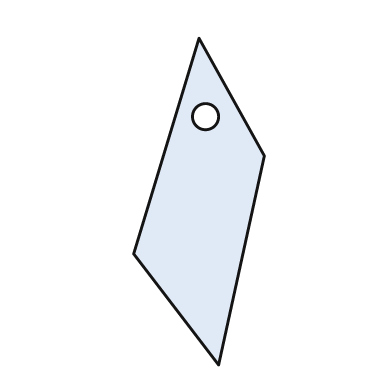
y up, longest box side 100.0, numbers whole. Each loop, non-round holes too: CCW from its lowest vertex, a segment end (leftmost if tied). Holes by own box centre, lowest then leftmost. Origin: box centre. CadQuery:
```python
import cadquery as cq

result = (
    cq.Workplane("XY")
    .moveTo(6.0, -50.0)
    .lineTo(20.0, 14.0)
    .lineTo(0.0, 50.0)
    .lineTo(-20.0, -16.0)
    .close()
    .moveTo(2.0, 26.0)
    .circle(4.0)
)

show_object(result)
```